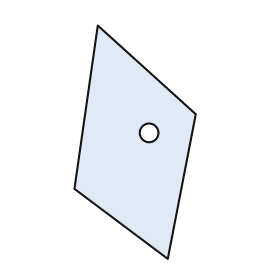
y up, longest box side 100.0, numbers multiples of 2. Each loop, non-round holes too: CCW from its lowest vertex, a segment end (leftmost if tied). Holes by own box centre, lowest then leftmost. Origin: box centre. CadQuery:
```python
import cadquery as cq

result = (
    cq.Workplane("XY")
    .moveTo(14.0, -50.0)
    .lineTo(26.0, 12.0)
    .lineTo(-16.0, 50.0)
    .lineTo(-26.0, -20.0)
    .close()
    .moveTo(6.0, 4.0)
    .circle(4.0)
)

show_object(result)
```